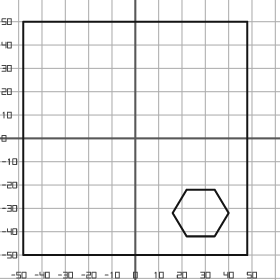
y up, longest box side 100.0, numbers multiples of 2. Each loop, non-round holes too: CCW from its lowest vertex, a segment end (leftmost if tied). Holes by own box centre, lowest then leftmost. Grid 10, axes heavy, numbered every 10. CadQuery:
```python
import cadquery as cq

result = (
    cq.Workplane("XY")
    .moveTo(-48.0, -50.0)
    .lineTo(48.0, -50.0)
    .lineTo(48.0, 50.0)
    .lineTo(-48.0, 50.0)
    .close()
    .moveTo(22.0, -42.0)
    .lineTo(34.0, -42.0)
    .lineTo(40.0, -32.0)
    .lineTo(34.0, -22.0)
    .lineTo(22.0, -22.0)
    .lineTo(16.0, -32.0)
    .close()
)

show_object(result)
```